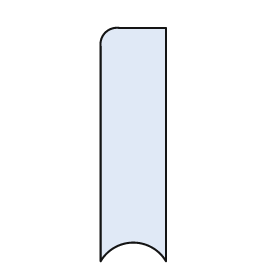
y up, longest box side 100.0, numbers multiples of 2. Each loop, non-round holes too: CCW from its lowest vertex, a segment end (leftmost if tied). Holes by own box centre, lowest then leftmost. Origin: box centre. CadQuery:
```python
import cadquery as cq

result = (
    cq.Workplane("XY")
    .moveTo(-14.0, -50.0)
    .threePointArc((0.0, -42.0), (14.0, -50.0))
    .lineTo(14.0, 50.0)
    .lineTo(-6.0, 50.0)
    .threePointArc((-12.0, 48.0), (-14.0, 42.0))
    .close()
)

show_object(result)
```